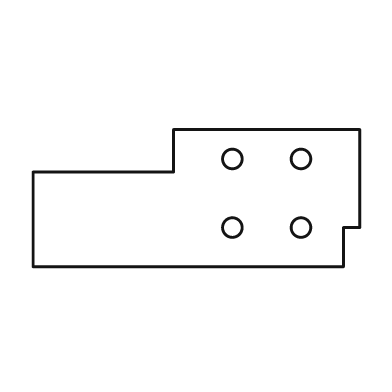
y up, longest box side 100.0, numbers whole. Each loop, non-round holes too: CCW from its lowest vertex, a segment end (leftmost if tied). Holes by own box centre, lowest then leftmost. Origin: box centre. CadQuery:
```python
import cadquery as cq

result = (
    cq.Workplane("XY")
    .moveTo(-50.0, -21.0)
    .lineTo(45.0, -21.0)
    .lineTo(45.0, -9.0)
    .lineTo(50.0, -9.0)
    .lineTo(50.0, 21.0)
    .lineTo(-7.0, 21.0)
    .lineTo(-7.0, 8.0)
    .lineTo(-50.0, 8.0)
    .close()
    .moveTo(11.0, -9.0)
    .circle(3.0)
    .moveTo(32.0, -9.0)
    .circle(3.0)
    .moveTo(11.0, 12.0)
    .circle(3.0)
    .moveTo(32.0, 12.0)
    .circle(3.0)
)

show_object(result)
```